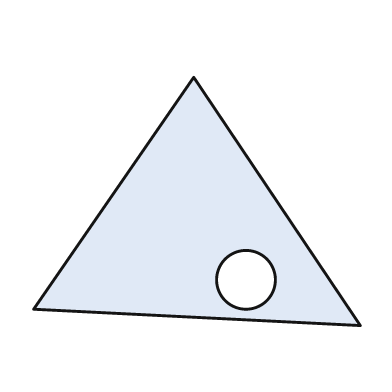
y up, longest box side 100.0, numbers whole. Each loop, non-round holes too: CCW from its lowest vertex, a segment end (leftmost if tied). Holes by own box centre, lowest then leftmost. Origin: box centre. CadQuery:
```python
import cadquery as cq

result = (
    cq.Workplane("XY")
    .moveTo(50.0, -38.0)
    .lineTo(-1.0, 38.0)
    .lineTo(-50.0, -33.0)
    .close()
    .moveTo(15.0, -24.0)
    .circle(9.0)
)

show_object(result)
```